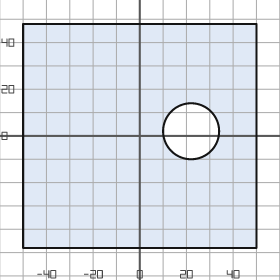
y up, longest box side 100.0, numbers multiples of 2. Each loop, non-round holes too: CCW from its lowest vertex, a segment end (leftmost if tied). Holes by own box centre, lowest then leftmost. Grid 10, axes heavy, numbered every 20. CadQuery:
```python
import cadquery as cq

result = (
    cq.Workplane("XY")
    .moveTo(-50.0, -48.0)
    .lineTo(50.0, -48.0)
    .lineTo(50.0, 48.0)
    .lineTo(-50.0, 48.0)
    .close()
    .moveTo(22.0, 2.0)
    .circle(12.0)
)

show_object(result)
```